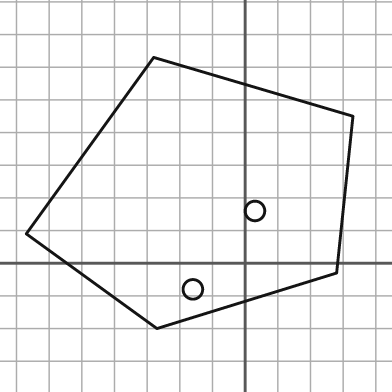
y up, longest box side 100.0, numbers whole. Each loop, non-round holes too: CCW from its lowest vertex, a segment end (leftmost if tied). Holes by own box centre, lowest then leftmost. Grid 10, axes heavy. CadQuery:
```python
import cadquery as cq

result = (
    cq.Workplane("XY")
    .moveTo(-27.0, -20.0)
    .lineTo(28.0, -3.0)
    .lineTo(33.0, 45.0)
    .lineTo(-28.0, 63.0)
    .lineTo(-67.0, 9.0)
    .close()
    .moveTo(-16.0, -8.0)
    .circle(3.0)
    .moveTo(3.0, 16.0)
    .circle(3.0)
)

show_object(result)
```